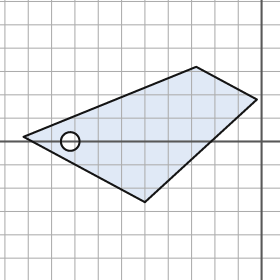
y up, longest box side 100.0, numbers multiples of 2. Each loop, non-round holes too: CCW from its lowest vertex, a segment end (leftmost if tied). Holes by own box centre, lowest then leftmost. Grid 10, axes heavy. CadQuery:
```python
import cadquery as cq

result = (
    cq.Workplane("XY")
    .moveTo(-50.0, -26.0)
    .lineTo(-2.0, 18.0)
    .lineTo(-28.0, 32.0)
    .lineTo(-102.0, 2.0)
    .close()
    .moveTo(-82.0, 0.0)
    .circle(4.0)
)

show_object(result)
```